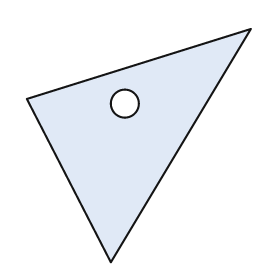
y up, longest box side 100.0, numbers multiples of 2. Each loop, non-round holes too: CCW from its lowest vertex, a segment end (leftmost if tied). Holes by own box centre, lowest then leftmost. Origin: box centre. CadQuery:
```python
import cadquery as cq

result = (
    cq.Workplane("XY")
    .moveTo(-12.0, -50.0)
    .lineTo(48.0, 50.0)
    .lineTo(-48.0, 20.0)
    .close()
    .moveTo(-6.0, 18.0)
    .circle(6.0)
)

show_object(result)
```